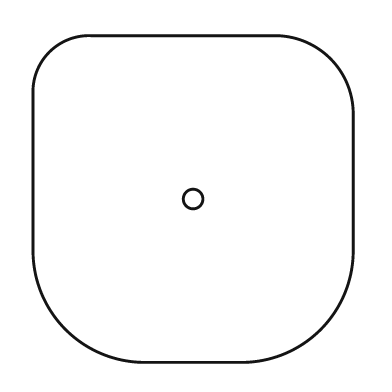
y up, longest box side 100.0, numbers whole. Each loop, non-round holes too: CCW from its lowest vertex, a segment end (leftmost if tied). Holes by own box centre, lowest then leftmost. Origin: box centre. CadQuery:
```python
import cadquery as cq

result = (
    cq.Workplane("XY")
    .moveTo(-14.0, -50.0)
    .lineTo(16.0, -50.0)
    .threePointArc((39.0, -40.0), (49.0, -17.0))
    .lineTo(49.0, 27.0)
    .threePointArc((42.0, 43.0), (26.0, 50.0))
    .lineTo(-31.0, 50.0)
    .threePointArc((-44.0, 45.0), (-49.0, 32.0))
    .lineTo(-49.0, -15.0)
    .threePointArc((-39.0, -40.0), (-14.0, -50.0))
    .close()
    .moveTo(0.0, 0.0)
    .circle(3.0)
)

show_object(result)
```